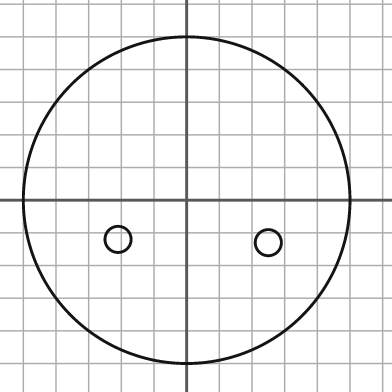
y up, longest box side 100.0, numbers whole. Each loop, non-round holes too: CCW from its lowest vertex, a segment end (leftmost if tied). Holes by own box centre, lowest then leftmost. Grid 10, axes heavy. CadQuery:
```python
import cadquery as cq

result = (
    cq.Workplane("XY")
    .moveTo(0.0, 0.0)
    .circle(50.0)
    .moveTo(25.0, -13.0)
    .circle(4.0)
    .moveTo(-21.0, -12.0)
    .circle(4.0)
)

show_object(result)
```